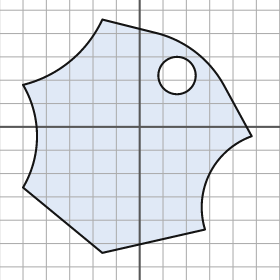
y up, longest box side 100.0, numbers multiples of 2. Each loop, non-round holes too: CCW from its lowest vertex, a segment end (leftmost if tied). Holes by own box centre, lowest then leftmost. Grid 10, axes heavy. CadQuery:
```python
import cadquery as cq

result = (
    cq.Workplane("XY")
    .moveTo(-16.0, -54.0)
    .lineTo(28.0, -44.0)
    .threePointArc((30.0, -20.0), (48.0, -4.0))
    .lineTo(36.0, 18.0)
    .threePointArc((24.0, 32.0), (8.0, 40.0))
    .lineTo(-16.0, 46.0)
    .threePointArc((-30.0, 28.0), (-50.0, 18.0))
    .threePointArc((-44.0, -4.0), (-50.0, -26.0))
    .close()
    .moveTo(16.0, 22.0)
    .circle(8.0)
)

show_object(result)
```